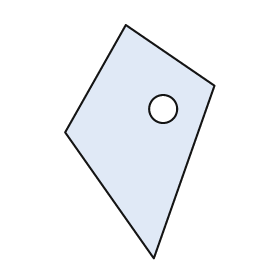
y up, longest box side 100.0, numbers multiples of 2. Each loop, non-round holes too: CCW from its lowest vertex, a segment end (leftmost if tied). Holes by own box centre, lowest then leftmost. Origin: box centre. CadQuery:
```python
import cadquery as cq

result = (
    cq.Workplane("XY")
    .moveTo(6.0, -50.0)
    .lineTo(32.0, 24.0)
    .lineTo(-6.0, 50.0)
    .lineTo(-32.0, 4.0)
    .close()
    .moveTo(10.0, 14.0)
    .circle(6.0)
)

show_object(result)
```